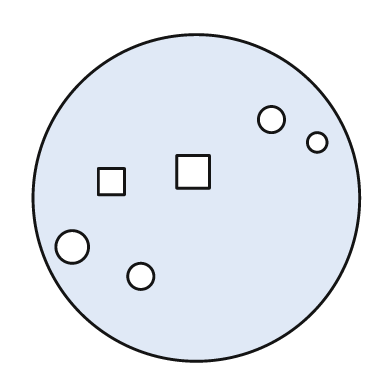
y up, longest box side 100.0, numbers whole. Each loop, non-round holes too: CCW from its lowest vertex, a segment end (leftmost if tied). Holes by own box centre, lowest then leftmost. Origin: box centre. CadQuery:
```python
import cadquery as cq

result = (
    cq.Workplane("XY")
    .moveTo(0.0, 0.0)
    .circle(50.0)
    .moveTo(-17.0, -24.0)
    .circle(4.0)
    .moveTo(-38.0, -15.0)
    .circle(5.0)
    .moveTo(-30.0, 1.0)
    .lineTo(-22.0, 1.0)
    .lineTo(-22.0, 9.0)
    .lineTo(-30.0, 9.0)
    .close()
    .moveTo(-6.0, 3.0)
    .lineTo(4.0, 3.0)
    .lineTo(4.0, 13.0)
    .lineTo(-6.0, 13.0)
    .close()
    .moveTo(37.0, 17.0)
    .circle(3.0)
    .moveTo(23.0, 24.0)
    .circle(4.0)
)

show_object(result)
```